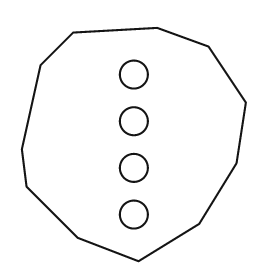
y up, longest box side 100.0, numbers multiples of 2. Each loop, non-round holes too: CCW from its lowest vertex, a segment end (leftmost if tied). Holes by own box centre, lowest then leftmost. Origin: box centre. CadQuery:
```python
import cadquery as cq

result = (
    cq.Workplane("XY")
    .moveTo(2.0, -50.0)
    .lineTo(28.0, -34.0)
    .lineTo(44.0, -8.0)
    .lineTo(48.0, 18.0)
    .lineTo(32.0, 42.0)
    .lineTo(10.0, 50.0)
    .lineTo(-26.0, 48.0)
    .lineTo(-40.0, 34.0)
    .lineTo(-48.0, -2.0)
    .lineTo(-46.0, -18.0)
    .lineTo(-24.0, -40.0)
    .close()
    .moveTo(0.0, -30.0)
    .circle(6.0)
    .moveTo(0.0, -10.0)
    .circle(6.0)
    .moveTo(0.0, 10.0)
    .circle(6.0)
    .moveTo(0.0, 30.0)
    .circle(6.0)
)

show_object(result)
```